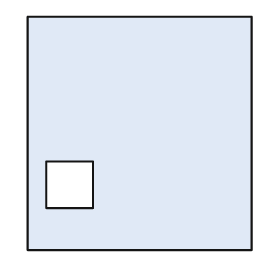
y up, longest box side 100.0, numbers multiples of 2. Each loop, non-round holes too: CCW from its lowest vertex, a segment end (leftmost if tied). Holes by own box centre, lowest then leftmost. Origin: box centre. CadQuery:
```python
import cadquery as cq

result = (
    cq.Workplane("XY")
    .moveTo(-48.0, -50.0)
    .lineTo(48.0, -50.0)
    .lineTo(48.0, 50.0)
    .lineTo(-48.0, 50.0)
    .close()
    .moveTo(-40.0, -32.0)
    .lineTo(-20.0, -32.0)
    .lineTo(-20.0, -12.0)
    .lineTo(-40.0, -12.0)
    .close()
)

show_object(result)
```